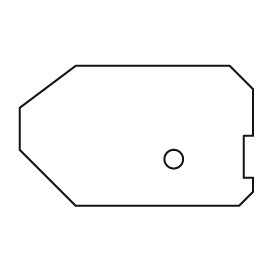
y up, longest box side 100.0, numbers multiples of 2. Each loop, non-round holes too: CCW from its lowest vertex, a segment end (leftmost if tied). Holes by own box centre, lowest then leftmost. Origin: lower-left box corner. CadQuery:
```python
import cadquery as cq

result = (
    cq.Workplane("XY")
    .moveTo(24.0, 0.0)
    .lineTo(94.0, 0.0)
    .lineTo(100.0, 6.0)
    .lineTo(100.0, 12.0)
    .lineTo(96.0, 12.0)
    .lineTo(96.0, 30.0)
    .lineTo(100.0, 30.0)
    .lineTo(100.0, 50.0)
    .lineTo(90.0, 60.0)
    .lineTo(24.0, 60.0)
    .lineTo(0.0, 42.0)
    .lineTo(0.0, 24.0)
    .close()
    .moveTo(66.0, 20.0)
    .circle(4.0)
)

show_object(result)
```